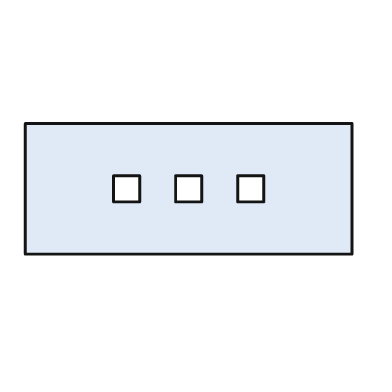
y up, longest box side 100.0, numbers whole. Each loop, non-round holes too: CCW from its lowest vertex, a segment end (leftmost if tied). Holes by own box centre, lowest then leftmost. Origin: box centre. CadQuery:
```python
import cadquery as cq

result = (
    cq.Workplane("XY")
    .moveTo(-50.0, -20.0)
    .lineTo(50.0, -20.0)
    .lineTo(50.0, 20.0)
    .lineTo(-50.0, 20.0)
    .close()
    .moveTo(-23.0, -4.0)
    .lineTo(-15.0, -4.0)
    .lineTo(-15.0, 4.0)
    .lineTo(-23.0, 4.0)
    .close()
    .moveTo(-4.0, -4.0)
    .lineTo(4.0, -4.0)
    .lineTo(4.0, 4.0)
    .lineTo(-4.0, 4.0)
    .close()
    .moveTo(15.0, -4.0)
    .lineTo(23.0, -4.0)
    .lineTo(23.0, 4.0)
    .lineTo(15.0, 4.0)
    .close()
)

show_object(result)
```